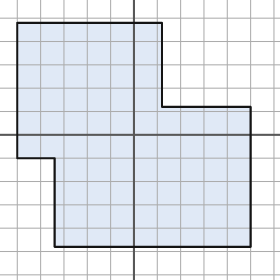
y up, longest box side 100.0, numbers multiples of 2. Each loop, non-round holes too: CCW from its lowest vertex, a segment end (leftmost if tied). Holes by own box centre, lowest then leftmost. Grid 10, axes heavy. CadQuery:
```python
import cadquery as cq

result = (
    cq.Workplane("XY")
    .moveTo(-34.0, -48.0)
    .lineTo(50.0, -48.0)
    .lineTo(50.0, 12.0)
    .lineTo(12.0, 12.0)
    .lineTo(12.0, 48.0)
    .lineTo(-50.0, 48.0)
    .lineTo(-50.0, -10.0)
    .lineTo(-34.0, -10.0)
    .close()
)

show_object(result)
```